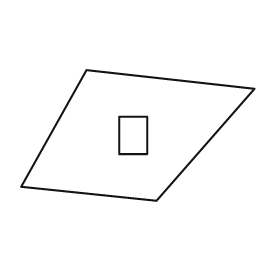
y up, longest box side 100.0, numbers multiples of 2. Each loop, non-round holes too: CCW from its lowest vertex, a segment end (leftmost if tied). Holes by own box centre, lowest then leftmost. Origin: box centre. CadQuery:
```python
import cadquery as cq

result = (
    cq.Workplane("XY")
    .moveTo(8.0, -28.0)
    .lineTo(50.0, 20.0)
    .lineTo(-22.0, 28.0)
    .lineTo(-50.0, -22.0)
    .close()
    .moveTo(-8.0, -8.0)
    .lineTo(4.0, -8.0)
    .lineTo(4.0, 8.0)
    .lineTo(-8.0, 8.0)
    .close()
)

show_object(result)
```